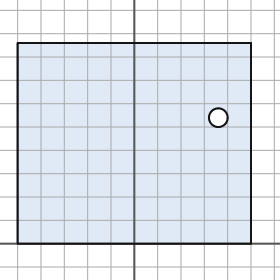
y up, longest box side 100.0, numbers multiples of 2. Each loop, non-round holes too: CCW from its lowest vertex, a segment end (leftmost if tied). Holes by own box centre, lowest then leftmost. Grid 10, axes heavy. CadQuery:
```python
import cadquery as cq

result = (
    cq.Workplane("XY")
    .moveTo(-50.0, 0.0)
    .lineTo(50.0, 0.0)
    .lineTo(50.0, 86.0)
    .lineTo(-50.0, 86.0)
    .close()
    .moveTo(36.0, 54.0)
    .circle(4.0)
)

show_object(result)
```